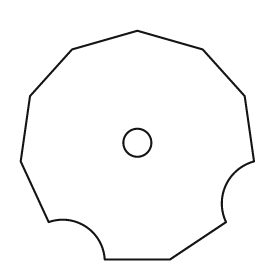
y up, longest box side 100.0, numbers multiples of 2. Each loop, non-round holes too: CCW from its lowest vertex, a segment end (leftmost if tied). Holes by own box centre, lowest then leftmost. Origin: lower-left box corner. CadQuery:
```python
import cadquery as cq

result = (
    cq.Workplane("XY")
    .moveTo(36.0, 0.0)
    .lineTo(64.0, 0.0)
    .lineTo(88.0, 16.0)
    .threePointArc((88.0, 32.0), (100.0, 42.0))
    .lineTo(96.0, 70.0)
    .lineTo(78.0, 90.0)
    .lineTo(50.0, 98.0)
    .lineTo(22.0, 90.0)
    .lineTo(4.0, 70.0)
    .lineTo(0.0, 42.0)
    .lineTo(12.0, 16.0)
    .threePointArc((28.0, 14.0), (36.0, 0.0))
    .close()
    .moveTo(50.0, 50.0)
    .circle(6.0)
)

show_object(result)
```